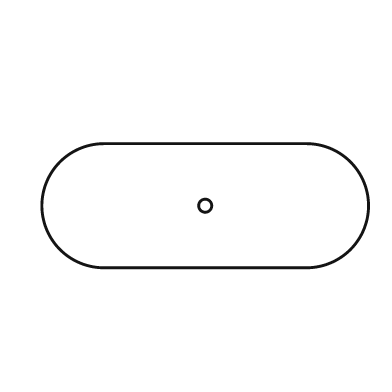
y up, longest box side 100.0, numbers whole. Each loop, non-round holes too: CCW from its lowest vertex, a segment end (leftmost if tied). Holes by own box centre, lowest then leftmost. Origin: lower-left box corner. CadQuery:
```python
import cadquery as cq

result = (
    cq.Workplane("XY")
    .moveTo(19.0, 0.0)
    .lineTo(81.0, 0.0)
    .threePointArc((100.0, 19.0), (81.0, 38.0))
    .lineTo(19.0, 38.0)
    .threePointArc((0.0, 19.0), (19.0, 0.0))
    .close()
    .moveTo(50.0, 19.0)
    .circle(2.0)
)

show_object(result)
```